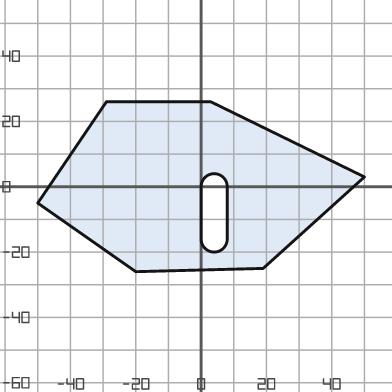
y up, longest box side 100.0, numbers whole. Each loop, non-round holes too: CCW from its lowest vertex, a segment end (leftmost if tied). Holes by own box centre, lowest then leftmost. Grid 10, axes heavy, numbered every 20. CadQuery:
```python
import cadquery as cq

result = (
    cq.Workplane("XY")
    .moveTo(-20.0, -26.0)
    .lineTo(19.0, -25.0)
    .lineTo(50.0, 3.0)
    .lineTo(3.0, 26.0)
    .lineTo(-29.0, 26.0)
    .lineTo(-50.0, -5.0)
    .close()
    .moveTo(0.0, -16.0)
    .threePointArc((4.0, -20.0), (8.0, -16.0))
    .lineTo(8.0, 0.0)
    .threePointArc((4.0, 4.0), (0.0, 0.0))
    .close()
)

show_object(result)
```